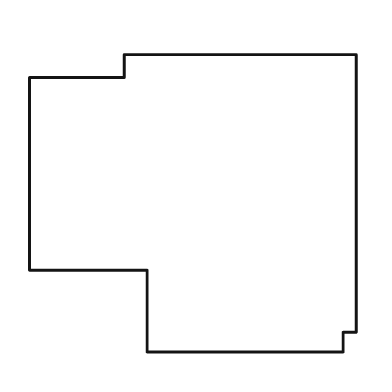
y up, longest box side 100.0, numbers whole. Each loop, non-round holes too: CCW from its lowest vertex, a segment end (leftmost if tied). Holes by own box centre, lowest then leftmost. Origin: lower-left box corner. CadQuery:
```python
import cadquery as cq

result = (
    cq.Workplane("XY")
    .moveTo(36.0, 0.0)
    .lineTo(96.0, 0.0)
    .lineTo(96.0, 6.0)
    .lineTo(100.0, 6.0)
    .lineTo(100.0, 91.0)
    .lineTo(29.0, 91.0)
    .lineTo(29.0, 84.0)
    .lineTo(0.0, 84.0)
    .lineTo(0.0, 25.0)
    .lineTo(36.0, 25.0)
    .close()
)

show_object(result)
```